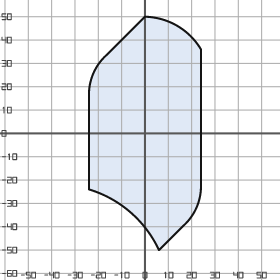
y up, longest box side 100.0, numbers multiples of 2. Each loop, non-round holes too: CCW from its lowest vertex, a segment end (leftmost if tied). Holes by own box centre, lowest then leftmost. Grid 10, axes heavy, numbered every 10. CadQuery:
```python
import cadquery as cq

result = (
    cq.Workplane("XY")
    .moveTo(6.0, -50.0)
    .lineTo(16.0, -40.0)
    .threePointArc((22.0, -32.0), (24.0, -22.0))
    .lineTo(24.0, 36.0)
    .threePointArc((14.0, 46.0), (0.0, 50.0))
    .lineTo(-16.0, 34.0)
    .threePointArc((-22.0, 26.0), (-24.0, 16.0))
    .lineTo(-24.0, -24.0)
    .threePointArc((-6.0, -34.0), (6.0, -50.0))
    .close()
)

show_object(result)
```